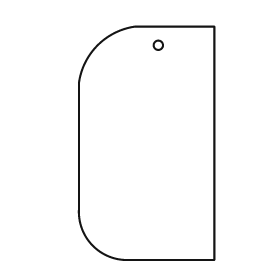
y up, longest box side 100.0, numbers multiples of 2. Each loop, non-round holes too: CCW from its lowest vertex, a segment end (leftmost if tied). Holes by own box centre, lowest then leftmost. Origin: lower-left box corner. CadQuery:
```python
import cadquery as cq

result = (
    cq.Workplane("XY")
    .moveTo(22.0, 0.0)
    .lineTo(58.0, 0.0)
    .lineTo(58.0, 100.0)
    .lineTo(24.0, 100.0)
    .threePointArc((8.0, 92.0), (0.0, 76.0))
    .lineTo(0.0, 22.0)
    .threePointArc((6.0, 6.0), (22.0, 0.0))
    .close()
    .moveTo(34.0, 92.0)
    .circle(2.0)
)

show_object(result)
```